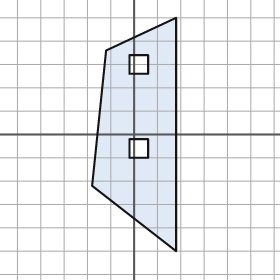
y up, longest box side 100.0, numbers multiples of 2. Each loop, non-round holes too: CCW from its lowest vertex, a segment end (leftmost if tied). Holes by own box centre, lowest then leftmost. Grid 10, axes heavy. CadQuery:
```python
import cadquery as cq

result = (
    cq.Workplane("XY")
    .moveTo(18.0, -50.0)
    .lineTo(18.0, 50.0)
    .lineTo(-12.0, 36.0)
    .lineTo(-18.0, -22.0)
    .close()
    .moveTo(-2.0, -10.0)
    .lineTo(6.0, -10.0)
    .lineTo(6.0, -2.0)
    .lineTo(-2.0, -2.0)
    .close()
    .moveTo(-2.0, 26.0)
    .lineTo(6.0, 26.0)
    .lineTo(6.0, 34.0)
    .lineTo(-2.0, 34.0)
    .close()
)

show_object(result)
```